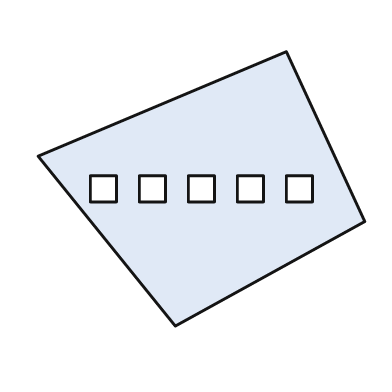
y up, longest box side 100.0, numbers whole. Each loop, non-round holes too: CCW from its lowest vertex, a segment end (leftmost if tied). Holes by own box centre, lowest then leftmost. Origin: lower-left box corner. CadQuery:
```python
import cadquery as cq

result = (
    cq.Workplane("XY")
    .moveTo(42.0, 0.0)
    .lineTo(100.0, 32.0)
    .lineTo(76.0, 84.0)
    .lineTo(0.0, 52.0)
    .close()
    .moveTo(16.0, 38.0)
    .lineTo(24.0, 38.0)
    .lineTo(24.0, 46.0)
    .lineTo(16.0, 46.0)
    .close()
    .moveTo(31.0, 38.0)
    .lineTo(39.0, 38.0)
    .lineTo(39.0, 46.0)
    .lineTo(31.0, 46.0)
    .close()
    .moveTo(46.0, 38.0)
    .lineTo(54.0, 38.0)
    .lineTo(54.0, 46.0)
    .lineTo(46.0, 46.0)
    .close()
    .moveTo(61.0, 38.0)
    .lineTo(69.0, 38.0)
    .lineTo(69.0, 46.0)
    .lineTo(61.0, 46.0)
    .close()
    .moveTo(76.0, 38.0)
    .lineTo(84.0, 38.0)
    .lineTo(84.0, 46.0)
    .lineTo(76.0, 46.0)
    .close()
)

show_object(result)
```